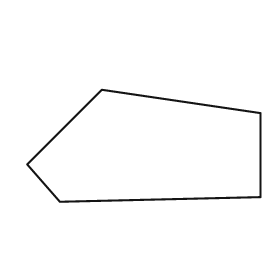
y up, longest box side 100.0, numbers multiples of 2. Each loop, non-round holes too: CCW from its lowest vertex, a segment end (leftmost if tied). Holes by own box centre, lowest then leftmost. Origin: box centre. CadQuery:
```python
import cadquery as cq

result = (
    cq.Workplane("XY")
    .moveTo(-36.0, -24.0)
    .lineTo(50.0, -22.0)
    .lineTo(50.0, 14.0)
    .lineTo(-18.0, 24.0)
    .lineTo(-50.0, -8.0)
    .close()
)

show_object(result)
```